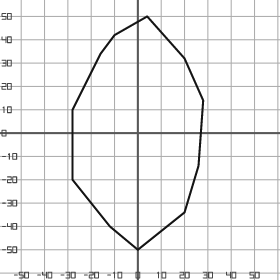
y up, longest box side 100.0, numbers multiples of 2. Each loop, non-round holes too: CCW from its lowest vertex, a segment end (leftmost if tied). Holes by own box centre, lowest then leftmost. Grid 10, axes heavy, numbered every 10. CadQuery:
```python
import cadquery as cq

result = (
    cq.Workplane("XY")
    .moveTo(0.0, -50.0)
    .lineTo(20.0, -34.0)
    .lineTo(26.0, -14.0)
    .lineTo(28.0, 14.0)
    .lineTo(20.0, 32.0)
    .lineTo(4.0, 50.0)
    .lineTo(-10.0, 42.0)
    .lineTo(-16.0, 34.0)
    .lineTo(-28.0, 10.0)
    .lineTo(-28.0, -20.0)
    .lineTo(-12.0, -40.0)
    .close()
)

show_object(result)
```